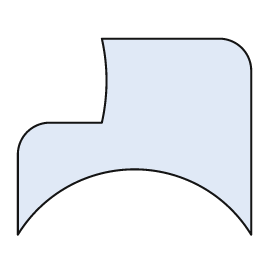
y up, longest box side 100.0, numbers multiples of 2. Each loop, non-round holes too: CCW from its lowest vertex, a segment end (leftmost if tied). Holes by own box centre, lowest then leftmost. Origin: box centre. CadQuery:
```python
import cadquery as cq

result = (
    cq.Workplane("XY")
    .moveTo(-50.0, -42.0)
    .threePointArc((0.0, -14.0), (50.0, -42.0))
    .lineTo(50.0, 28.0)
    .threePointArc((46.0, 38.0), (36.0, 42.0))
    .lineTo(-14.0, 42.0)
    .threePointArc((-12.0, 24.0), (-14.0, 6.0))
    .lineTo(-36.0, 6.0)
    .threePointArc((-46.0, 2.0), (-50.0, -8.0))
    .close()
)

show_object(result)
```